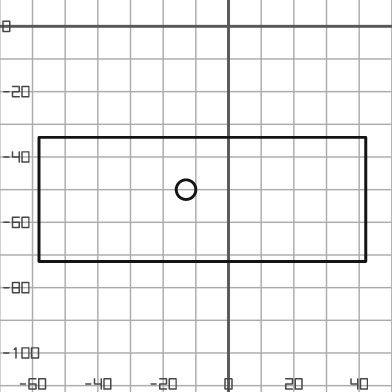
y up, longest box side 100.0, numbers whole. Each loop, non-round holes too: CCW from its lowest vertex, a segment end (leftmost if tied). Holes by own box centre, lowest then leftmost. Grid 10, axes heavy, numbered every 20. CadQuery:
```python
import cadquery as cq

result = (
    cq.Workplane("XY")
    .moveTo(-58.0, -72.0)
    .lineTo(42.0, -72.0)
    .lineTo(42.0, -34.0)
    .lineTo(-58.0, -34.0)
    .close()
    .moveTo(-13.0, -50.0)
    .circle(3.0)
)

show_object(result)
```